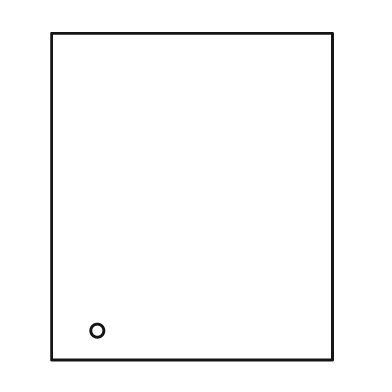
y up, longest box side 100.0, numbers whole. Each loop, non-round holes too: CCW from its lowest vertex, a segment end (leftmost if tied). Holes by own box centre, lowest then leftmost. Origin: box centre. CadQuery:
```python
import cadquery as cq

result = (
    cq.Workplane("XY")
    .moveTo(-43.0, -50.0)
    .lineTo(43.0, -50.0)
    .lineTo(43.0, 50.0)
    .lineTo(-43.0, 50.0)
    .close()
    .moveTo(-29.0, -41.0)
    .circle(2.0)
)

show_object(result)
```